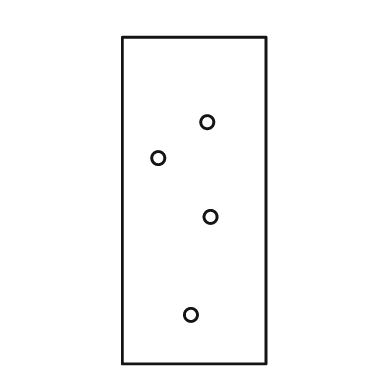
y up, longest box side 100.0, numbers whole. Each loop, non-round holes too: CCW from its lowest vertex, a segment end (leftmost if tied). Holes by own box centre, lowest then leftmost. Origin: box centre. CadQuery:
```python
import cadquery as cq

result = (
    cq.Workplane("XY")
    .moveTo(-22.0, -50.0)
    .lineTo(22.0, -50.0)
    .lineTo(22.0, 50.0)
    .lineTo(-22.0, 50.0)
    .close()
    .moveTo(-1.0, -35.0)
    .circle(2.0)
    .moveTo(5.0, -5.0)
    .circle(2.0)
    .moveTo(-11.0, 13.0)
    .circle(2.0)
    .moveTo(4.0, 24.0)
    .circle(2.0)
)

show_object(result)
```